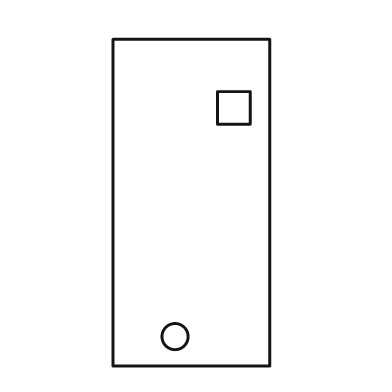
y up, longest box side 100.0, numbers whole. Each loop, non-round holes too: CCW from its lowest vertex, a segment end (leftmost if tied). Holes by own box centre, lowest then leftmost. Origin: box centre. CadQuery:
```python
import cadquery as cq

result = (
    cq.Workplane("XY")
    .moveTo(-24.0, -50.0)
    .lineTo(24.0, -50.0)
    .lineTo(24.0, 50.0)
    .lineTo(-24.0, 50.0)
    .close()
    .moveTo(-5.0, -41.0)
    .circle(4.0)
    .moveTo(8.0, 24.0)
    .lineTo(18.0, 24.0)
    .lineTo(18.0, 34.0)
    .lineTo(8.0, 34.0)
    .close()
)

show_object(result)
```